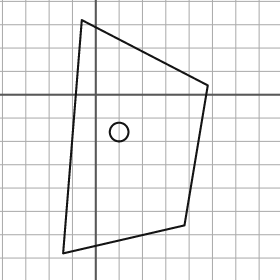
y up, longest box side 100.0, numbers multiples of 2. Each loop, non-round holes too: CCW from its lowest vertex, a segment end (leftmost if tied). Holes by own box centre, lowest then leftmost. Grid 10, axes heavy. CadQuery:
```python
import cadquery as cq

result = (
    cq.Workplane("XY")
    .moveTo(-14.0, -68.0)
    .lineTo(38.0, -56.0)
    .lineTo(48.0, 4.0)
    .lineTo(-6.0, 32.0)
    .close()
    .moveTo(10.0, -16.0)
    .circle(4.0)
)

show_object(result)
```